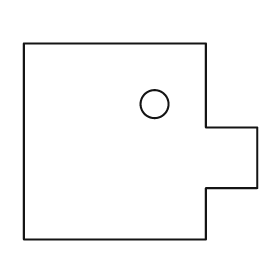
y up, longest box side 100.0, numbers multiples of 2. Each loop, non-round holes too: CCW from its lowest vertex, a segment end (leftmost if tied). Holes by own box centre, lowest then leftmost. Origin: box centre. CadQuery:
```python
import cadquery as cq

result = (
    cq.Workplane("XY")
    .moveTo(-50.0, -42.0)
    .lineTo(28.0, -42.0)
    .lineTo(28.0, -20.0)
    .lineTo(50.0, -20.0)
    .lineTo(50.0, 6.0)
    .lineTo(28.0, 6.0)
    .lineTo(28.0, 42.0)
    .lineTo(-50.0, 42.0)
    .close()
    .moveTo(6.0, 16.0)
    .circle(6.0)
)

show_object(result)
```